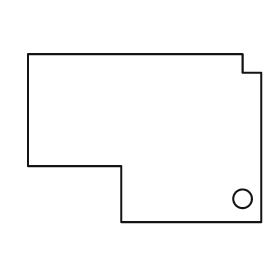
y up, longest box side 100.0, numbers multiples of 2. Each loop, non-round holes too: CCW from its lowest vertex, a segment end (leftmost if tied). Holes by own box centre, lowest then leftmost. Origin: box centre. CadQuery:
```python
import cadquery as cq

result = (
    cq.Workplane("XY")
    .moveTo(-10.0, -36.0)
    .lineTo(50.0, -36.0)
    .lineTo(50.0, 28.0)
    .lineTo(42.0, 28.0)
    .lineTo(42.0, 36.0)
    .lineTo(-50.0, 36.0)
    .lineTo(-50.0, -12.0)
    .lineTo(-10.0, -12.0)
    .close()
    .moveTo(42.0, -26.0)
    .circle(4.0)
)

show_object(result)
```